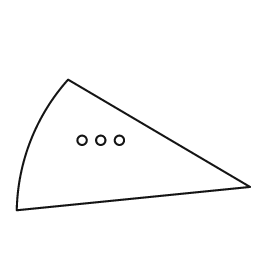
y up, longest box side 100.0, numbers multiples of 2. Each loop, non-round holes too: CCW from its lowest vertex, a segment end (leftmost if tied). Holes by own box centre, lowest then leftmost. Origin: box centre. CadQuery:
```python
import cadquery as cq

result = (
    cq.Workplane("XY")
    .moveTo(-50.0, -28.0)
    .lineTo(50.0, -18.0)
    .lineTo(-28.0, 28.0)
    .threePointArc((-44.0, 2.0), (-50.0, -28.0))
    .close()
    .moveTo(-22.0, 2.0)
    .circle(2.0)
    .moveTo(-14.0, 2.0)
    .circle(2.0)
    .moveTo(-6.0, 2.0)
    .circle(2.0)
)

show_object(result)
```